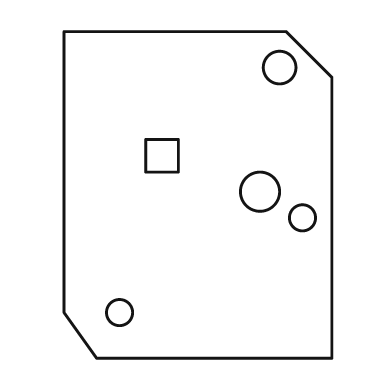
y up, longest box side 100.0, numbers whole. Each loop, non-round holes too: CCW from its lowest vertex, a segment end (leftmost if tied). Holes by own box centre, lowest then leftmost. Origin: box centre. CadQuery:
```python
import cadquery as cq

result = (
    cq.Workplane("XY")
    .moveTo(-31.0, -50.0)
    .lineTo(41.0, -50.0)
    .lineTo(41.0, 36.0)
    .lineTo(27.0, 50.0)
    .lineTo(-41.0, 50.0)
    .lineTo(-41.0, -36.0)
    .close()
    .moveTo(-24.0, -36.0)
    .circle(4.0)
    .moveTo(32.0, -7.0)
    .circle(4.0)
    .moveTo(19.0, 1.0)
    .circle(6.0)
    .moveTo(-16.0, 7.0)
    .lineTo(-6.0, 7.0)
    .lineTo(-6.0, 17.0)
    .lineTo(-16.0, 17.0)
    .close()
    .moveTo(25.0, 39.0)
    .circle(5.0)
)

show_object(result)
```